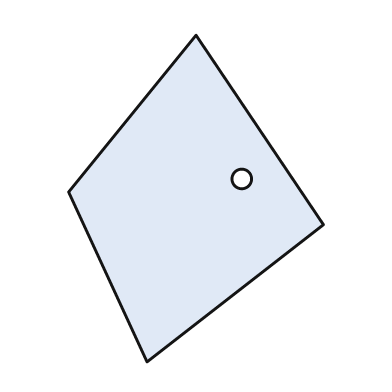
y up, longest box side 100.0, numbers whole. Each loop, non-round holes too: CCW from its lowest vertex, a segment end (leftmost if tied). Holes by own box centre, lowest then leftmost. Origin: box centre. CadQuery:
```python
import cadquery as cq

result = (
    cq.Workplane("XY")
    .moveTo(-15.0, -50.0)
    .lineTo(39.0, -8.0)
    .lineTo(0.0, 50.0)
    .lineTo(-39.0, 2.0)
    .close()
    .moveTo(14.0, 6.0)
    .circle(3.0)
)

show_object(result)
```